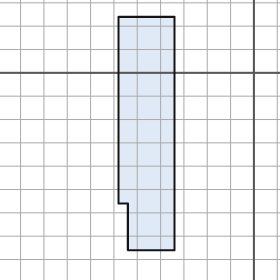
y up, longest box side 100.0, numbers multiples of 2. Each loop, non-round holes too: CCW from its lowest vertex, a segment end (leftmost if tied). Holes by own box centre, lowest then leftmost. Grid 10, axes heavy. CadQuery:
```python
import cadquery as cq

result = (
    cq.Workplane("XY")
    .moveTo(-54.0, -76.0)
    .lineTo(-34.0, -76.0)
    .lineTo(-34.0, 24.0)
    .lineTo(-58.0, 24.0)
    .lineTo(-58.0, -56.0)
    .lineTo(-54.0, -56.0)
    .close()
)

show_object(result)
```